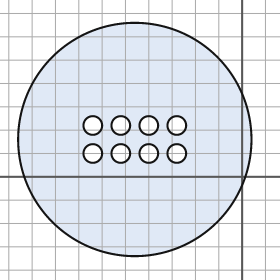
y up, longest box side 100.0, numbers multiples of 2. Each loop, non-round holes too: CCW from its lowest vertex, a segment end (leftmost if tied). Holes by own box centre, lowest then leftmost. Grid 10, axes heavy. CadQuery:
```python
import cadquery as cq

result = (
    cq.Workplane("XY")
    .moveTo(-46.0, 16.0)
    .circle(50.0)
    .moveTo(-64.0, 10.0)
    .circle(4.0)
    .moveTo(-52.0, 10.0)
    .circle(4.0)
    .moveTo(-40.0, 10.0)
    .circle(4.0)
    .moveTo(-28.0, 10.0)
    .circle(4.0)
    .moveTo(-64.0, 22.0)
    .circle(4.0)
    .moveTo(-52.0, 22.0)
    .circle(4.0)
    .moveTo(-40.0, 22.0)
    .circle(4.0)
    .moveTo(-28.0, 22.0)
    .circle(4.0)
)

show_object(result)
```